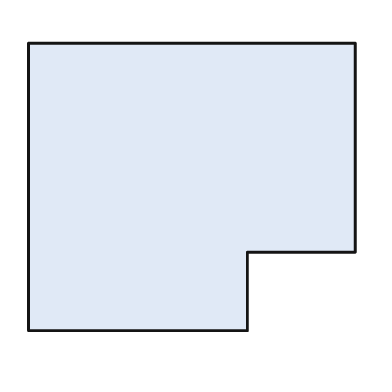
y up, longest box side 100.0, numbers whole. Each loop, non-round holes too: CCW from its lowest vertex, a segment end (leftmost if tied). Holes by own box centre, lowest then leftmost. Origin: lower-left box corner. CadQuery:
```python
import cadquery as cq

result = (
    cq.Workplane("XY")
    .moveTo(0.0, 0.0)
    .lineTo(67.0, 0.0)
    .lineTo(67.0, 24.0)
    .lineTo(100.0, 24.0)
    .lineTo(100.0, 88.0)
    .lineTo(0.0, 88.0)
    .close()
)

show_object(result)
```